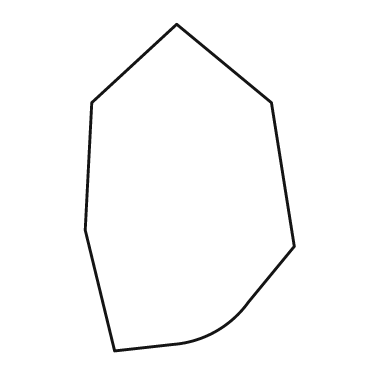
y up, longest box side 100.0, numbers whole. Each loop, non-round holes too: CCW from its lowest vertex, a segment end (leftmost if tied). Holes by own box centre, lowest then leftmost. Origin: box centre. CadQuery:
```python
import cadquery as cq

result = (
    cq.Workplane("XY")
    .moveTo(-23.0, -50.0)
    .lineTo(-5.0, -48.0)
    .threePointArc((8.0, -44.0), (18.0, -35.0))
    .lineTo(32.0, -18.0)
    .lineTo(25.0, 26.0)
    .lineTo(-4.0, 50.0)
    .lineTo(-30.0, 26.0)
    .lineTo(-32.0, -13.0)
    .close()
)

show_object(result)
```